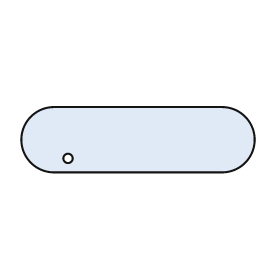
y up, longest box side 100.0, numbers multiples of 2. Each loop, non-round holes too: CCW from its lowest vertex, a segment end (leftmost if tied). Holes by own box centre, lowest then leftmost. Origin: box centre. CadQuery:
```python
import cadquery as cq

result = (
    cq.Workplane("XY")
    .moveTo(-36.0, -14.0)
    .lineTo(36.0, -14.0)
    .threePointArc((50.0, 0.0), (36.0, 14.0))
    .lineTo(-36.0, 14.0)
    .threePointArc((-50.0, 0.0), (-36.0, -14.0))
    .close()
    .moveTo(-30.0, -8.0)
    .circle(2.0)
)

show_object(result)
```